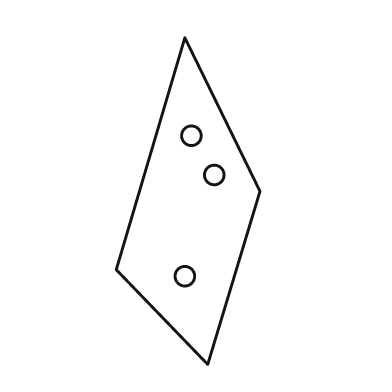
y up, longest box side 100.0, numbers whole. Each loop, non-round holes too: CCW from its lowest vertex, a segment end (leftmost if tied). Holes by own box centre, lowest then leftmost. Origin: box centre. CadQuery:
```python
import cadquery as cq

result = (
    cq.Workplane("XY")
    .moveTo(6.0, -50.0)
    .lineTo(22.0, 3.0)
    .lineTo(-1.0, 50.0)
    .lineTo(-22.0, -21.0)
    .close()
    .moveTo(-1.0, -23.0)
    .circle(3.0)
    .moveTo(8.0, 8.0)
    .circle(3.0)
    .moveTo(1.0, 20.0)
    .circle(3.0)
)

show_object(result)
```